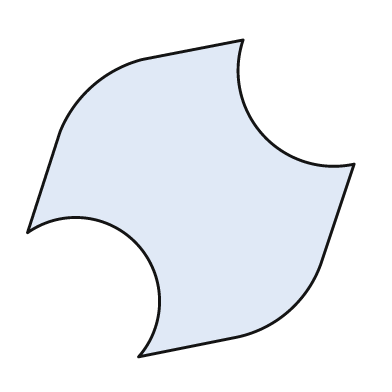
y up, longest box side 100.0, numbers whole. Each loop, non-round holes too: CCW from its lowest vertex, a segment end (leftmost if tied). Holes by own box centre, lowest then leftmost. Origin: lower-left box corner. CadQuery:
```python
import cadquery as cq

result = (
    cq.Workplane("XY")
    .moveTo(34.0, 0.0)
    .lineTo(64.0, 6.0)
    .threePointArc((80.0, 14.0), (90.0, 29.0))
    .lineTo(100.0, 59.0)
    .threePointArc((72.0, 68.0), (66.0, 97.0))
    .lineTo(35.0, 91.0)
    .threePointArc((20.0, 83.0), (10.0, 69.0))
    .lineTo(0.0, 38.0)
    .threePointArc((34.0, 34.0), (34.0, 0.0))
    .close()
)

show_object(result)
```